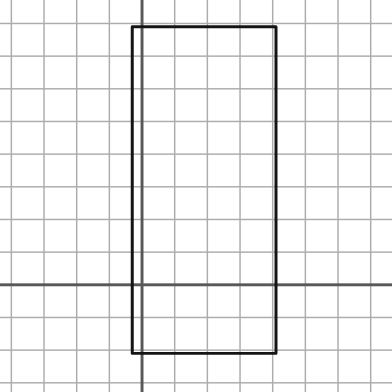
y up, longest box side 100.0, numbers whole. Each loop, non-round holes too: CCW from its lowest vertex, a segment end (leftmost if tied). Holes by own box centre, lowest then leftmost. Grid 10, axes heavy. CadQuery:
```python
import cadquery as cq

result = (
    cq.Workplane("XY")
    .moveTo(-3.0, -21.0)
    .lineTo(41.0, -21.0)
    .lineTo(41.0, 79.0)
    .lineTo(-3.0, 79.0)
    .close()
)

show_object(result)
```